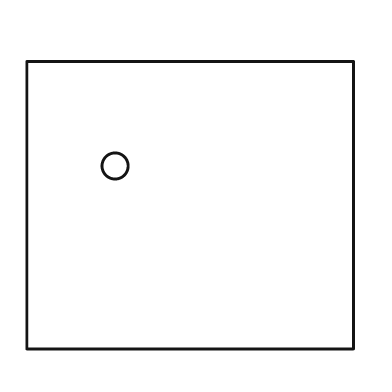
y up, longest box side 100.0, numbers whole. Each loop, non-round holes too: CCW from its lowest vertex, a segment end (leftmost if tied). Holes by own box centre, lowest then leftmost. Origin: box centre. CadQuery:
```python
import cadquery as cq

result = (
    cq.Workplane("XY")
    .moveTo(-50.0, -44.0)
    .lineTo(50.0, -44.0)
    .lineTo(50.0, 44.0)
    .lineTo(-50.0, 44.0)
    .close()
    .moveTo(-23.0, 12.0)
    .circle(4.0)
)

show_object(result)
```